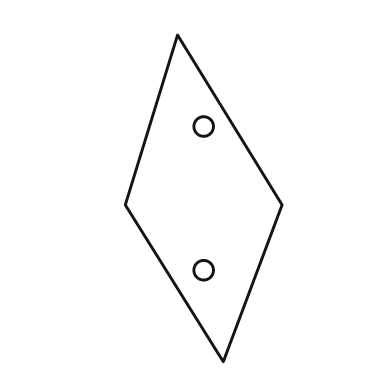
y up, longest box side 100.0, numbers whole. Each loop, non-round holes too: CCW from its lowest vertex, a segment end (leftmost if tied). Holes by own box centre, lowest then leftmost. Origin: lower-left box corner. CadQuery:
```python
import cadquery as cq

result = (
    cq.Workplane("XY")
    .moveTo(30.0, 0.0)
    .lineTo(48.0, 48.0)
    .lineTo(16.0, 100.0)
    .lineTo(0.0, 48.0)
    .close()
    .moveTo(24.0, 28.0)
    .circle(3.0)
    .moveTo(24.0, 72.0)
    .circle(3.0)
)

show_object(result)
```